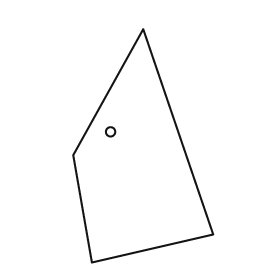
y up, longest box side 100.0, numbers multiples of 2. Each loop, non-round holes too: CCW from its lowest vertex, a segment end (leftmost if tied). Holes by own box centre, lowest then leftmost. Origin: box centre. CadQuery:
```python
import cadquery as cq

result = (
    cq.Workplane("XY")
    .moveTo(-22.0, -50.0)
    .lineTo(30.0, -38.0)
    .lineTo(0.0, 50.0)
    .lineTo(-30.0, -4.0)
    .close()
    .moveTo(-14.0, 6.0)
    .circle(2.0)
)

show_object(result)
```